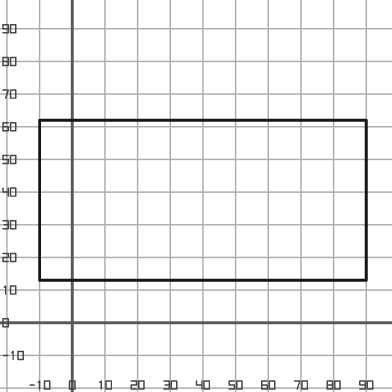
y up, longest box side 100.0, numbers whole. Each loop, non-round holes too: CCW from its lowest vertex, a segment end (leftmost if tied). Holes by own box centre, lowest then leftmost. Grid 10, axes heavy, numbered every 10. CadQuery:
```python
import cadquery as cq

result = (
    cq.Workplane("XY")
    .moveTo(-10.0, 13.0)
    .lineTo(90.0, 13.0)
    .lineTo(90.0, 62.0)
    .lineTo(-10.0, 62.0)
    .close()
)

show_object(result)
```